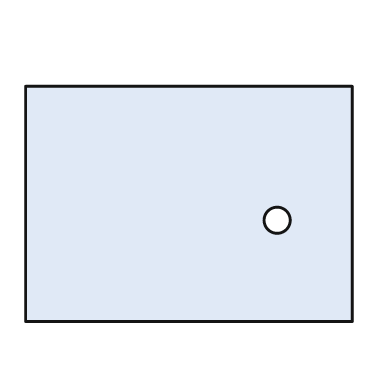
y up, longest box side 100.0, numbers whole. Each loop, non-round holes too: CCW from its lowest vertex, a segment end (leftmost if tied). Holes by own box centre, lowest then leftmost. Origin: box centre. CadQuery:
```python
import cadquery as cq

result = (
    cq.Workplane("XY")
    .moveTo(-50.0, -36.0)
    .lineTo(50.0, -36.0)
    .lineTo(50.0, 36.0)
    .lineTo(-50.0, 36.0)
    .close()
    .moveTo(27.0, -5.0)
    .circle(4.0)
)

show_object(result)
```